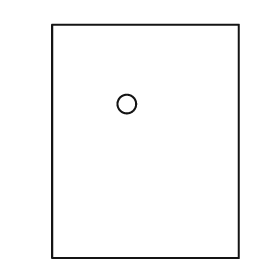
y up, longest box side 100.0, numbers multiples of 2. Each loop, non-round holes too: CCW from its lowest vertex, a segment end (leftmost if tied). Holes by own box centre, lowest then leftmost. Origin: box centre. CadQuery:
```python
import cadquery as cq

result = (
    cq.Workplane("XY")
    .moveTo(-40.0, -50.0)
    .lineTo(40.0, -50.0)
    .lineTo(40.0, 50.0)
    .lineTo(-40.0, 50.0)
    .close()
    .moveTo(-8.0, 16.0)
    .circle(4.0)
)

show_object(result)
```